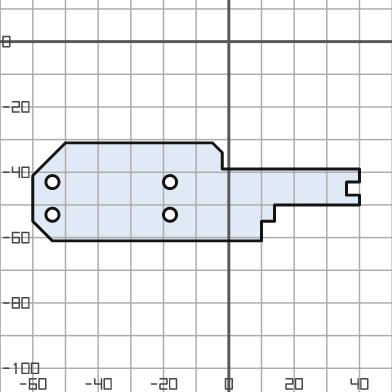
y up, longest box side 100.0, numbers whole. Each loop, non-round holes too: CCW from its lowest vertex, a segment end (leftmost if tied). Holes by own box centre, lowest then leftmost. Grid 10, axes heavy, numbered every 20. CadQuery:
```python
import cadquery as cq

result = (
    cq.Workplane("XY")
    .moveTo(-54.0, -61.0)
    .lineTo(10.0, -61.0)
    .lineTo(10.0, -55.0)
    .lineTo(14.0, -55.0)
    .lineTo(14.0, -50.0)
    .lineTo(40.0, -50.0)
    .lineTo(40.0, -47.0)
    .lineTo(36.0, -47.0)
    .lineTo(36.0, -43.0)
    .lineTo(40.0, -43.0)
    .lineTo(40.0, -39.0)
    .lineTo(-2.0, -39.0)
    .lineTo(-2.0, -34.0)
    .lineTo(-5.0, -31.0)
    .lineTo(-50.0, -31.0)
    .lineTo(-60.0, -41.0)
    .lineTo(-60.0, -55.0)
    .close()
    .moveTo(-54.0, -53.0)
    .circle(2.0)
    .moveTo(-18.0, -53.0)
    .circle(2.0)
    .moveTo(-54.0, -43.0)
    .circle(2.0)
    .moveTo(-18.0, -43.0)
    .circle(2.0)
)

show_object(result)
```